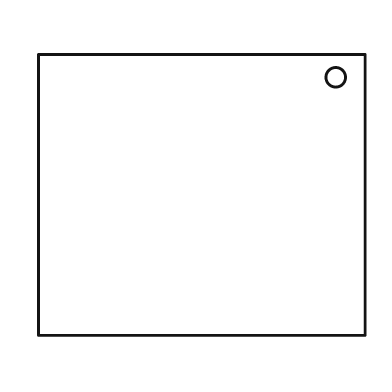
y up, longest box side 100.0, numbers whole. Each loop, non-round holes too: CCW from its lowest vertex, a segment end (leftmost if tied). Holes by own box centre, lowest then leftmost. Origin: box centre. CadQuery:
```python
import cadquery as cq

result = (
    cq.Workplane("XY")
    .moveTo(-50.0, -43.0)
    .lineTo(50.0, -43.0)
    .lineTo(50.0, 43.0)
    .lineTo(-50.0, 43.0)
    .close()
    .moveTo(41.0, 36.0)
    .circle(3.0)
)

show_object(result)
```